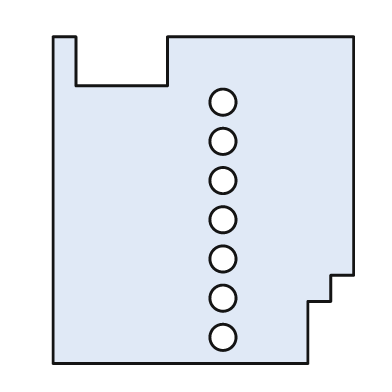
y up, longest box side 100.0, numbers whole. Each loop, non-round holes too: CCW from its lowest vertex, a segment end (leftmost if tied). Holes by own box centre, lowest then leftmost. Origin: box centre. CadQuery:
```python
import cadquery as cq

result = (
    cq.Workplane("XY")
    .moveTo(-46.0, -50.0)
    .lineTo(32.0, -50.0)
    .lineTo(32.0, -31.0)
    .lineTo(39.0, -31.0)
    .lineTo(39.0, -23.0)
    .lineTo(46.0, -23.0)
    .lineTo(46.0, 50.0)
    .lineTo(-11.0, 50.0)
    .lineTo(-11.0, 35.0)
    .lineTo(-39.0, 35.0)
    .lineTo(-39.0, 50.0)
    .lineTo(-46.0, 50.0)
    .close()
    .moveTo(6.0, -42.0)
    .circle(4.0)
    .moveTo(6.0, -30.0)
    .circle(4.0)
    .moveTo(6.0, -18.0)
    .circle(4.0)
    .moveTo(6.0, -6.0)
    .circle(4.0)
    .moveTo(6.0, 6.0)
    .circle(4.0)
    .moveTo(6.0, 18.0)
    .circle(4.0)
    .moveTo(6.0, 30.0)
    .circle(4.0)
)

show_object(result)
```